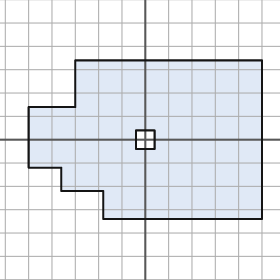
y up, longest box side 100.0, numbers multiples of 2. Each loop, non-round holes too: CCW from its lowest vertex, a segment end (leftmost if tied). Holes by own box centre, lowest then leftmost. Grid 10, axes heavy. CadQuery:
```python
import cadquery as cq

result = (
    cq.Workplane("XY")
    .moveTo(-18.0, -34.0)
    .lineTo(50.0, -34.0)
    .lineTo(50.0, 34.0)
    .lineTo(-30.0, 34.0)
    .lineTo(-30.0, 14.0)
    .lineTo(-50.0, 14.0)
    .lineTo(-50.0, -12.0)
    .lineTo(-36.0, -12.0)
    .lineTo(-36.0, -22.0)
    .lineTo(-18.0, -22.0)
    .close()
    .moveTo(-4.0, -4.0)
    .lineTo(4.0, -4.0)
    .lineTo(4.0, 4.0)
    .lineTo(-4.0, 4.0)
    .close()
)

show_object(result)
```